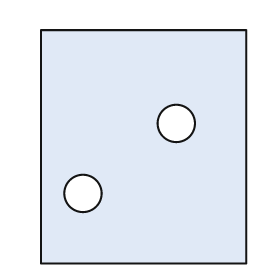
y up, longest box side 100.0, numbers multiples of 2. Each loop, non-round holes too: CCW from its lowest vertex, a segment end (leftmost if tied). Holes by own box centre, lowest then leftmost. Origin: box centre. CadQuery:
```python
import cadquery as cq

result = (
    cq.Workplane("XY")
    .moveTo(-44.0, -50.0)
    .lineTo(44.0, -50.0)
    .lineTo(44.0, 50.0)
    .lineTo(-44.0, 50.0)
    .close()
    .moveTo(-26.0, -20.0)
    .circle(8.0)
    .moveTo(14.0, 10.0)
    .circle(8.0)
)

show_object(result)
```